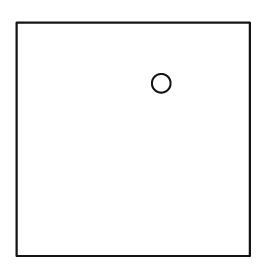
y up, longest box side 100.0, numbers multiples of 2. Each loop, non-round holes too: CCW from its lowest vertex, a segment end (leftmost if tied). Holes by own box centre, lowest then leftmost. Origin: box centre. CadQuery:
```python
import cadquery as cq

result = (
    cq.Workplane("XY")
    .moveTo(-50.0, -50.0)
    .lineTo(50.0, -50.0)
    .lineTo(50.0, 50.0)
    .lineTo(-50.0, 50.0)
    .close()
    .moveTo(12.0, 24.0)
    .circle(4.0)
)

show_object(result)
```